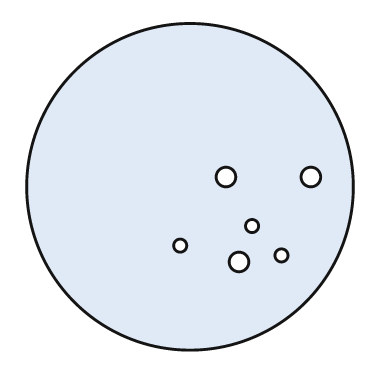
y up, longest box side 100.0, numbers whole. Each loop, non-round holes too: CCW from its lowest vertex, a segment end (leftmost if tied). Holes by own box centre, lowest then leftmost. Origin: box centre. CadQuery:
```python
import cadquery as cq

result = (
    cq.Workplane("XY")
    .moveTo(0.0, 0.0)
    .circle(50.0)
    .moveTo(15.0, -23.0)
    .circle(3.0)
    .moveTo(28.0, -21.0)
    .circle(2.0)
    .moveTo(-3.0, -18.0)
    .circle(2.0)
    .moveTo(19.0, -12.0)
    .circle(2.0)
    .moveTo(11.0, 3.0)
    .circle(3.0)
    .moveTo(37.0, 3.0)
    .circle(3.0)
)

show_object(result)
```